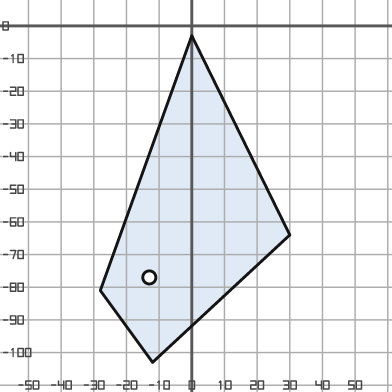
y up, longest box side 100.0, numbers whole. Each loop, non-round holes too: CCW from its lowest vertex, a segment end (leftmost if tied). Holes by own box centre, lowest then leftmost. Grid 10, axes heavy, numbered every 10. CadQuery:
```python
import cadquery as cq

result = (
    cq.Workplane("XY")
    .moveTo(-12.0, -103.0)
    .lineTo(30.0, -64.0)
    .lineTo(0.0, -3.0)
    .lineTo(-28.0, -81.0)
    .close()
    .moveTo(-13.0, -77.0)
    .circle(2.0)
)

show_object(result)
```